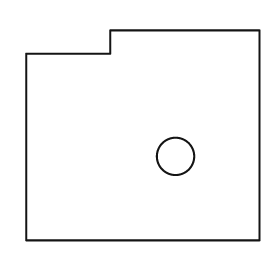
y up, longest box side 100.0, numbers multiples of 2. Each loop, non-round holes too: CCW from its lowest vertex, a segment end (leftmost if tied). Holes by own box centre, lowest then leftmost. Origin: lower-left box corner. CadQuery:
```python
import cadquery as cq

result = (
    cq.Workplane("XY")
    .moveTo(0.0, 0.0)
    .lineTo(100.0, 0.0)
    .lineTo(100.0, 90.0)
    .lineTo(36.0, 90.0)
    .lineTo(36.0, 80.0)
    .lineTo(0.0, 80.0)
    .close()
    .moveTo(64.0, 36.0)
    .circle(8.0)
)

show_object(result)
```